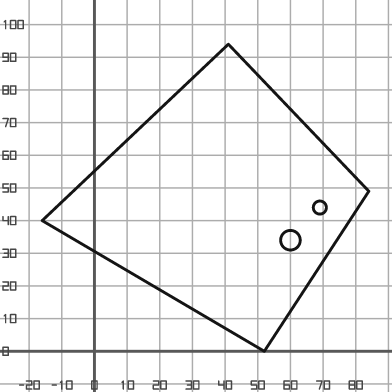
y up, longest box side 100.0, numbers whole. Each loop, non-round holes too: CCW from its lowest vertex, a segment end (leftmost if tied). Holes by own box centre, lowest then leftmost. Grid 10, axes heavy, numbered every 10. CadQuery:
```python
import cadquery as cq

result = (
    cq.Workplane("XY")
    .moveTo(52.0, 0.0)
    .lineTo(84.0, 49.0)
    .lineTo(41.0, 94.0)
    .lineTo(-16.0, 40.0)
    .close()
    .moveTo(60.0, 34.0)
    .circle(3.0)
    .moveTo(69.0, 44.0)
    .circle(2.0)
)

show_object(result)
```